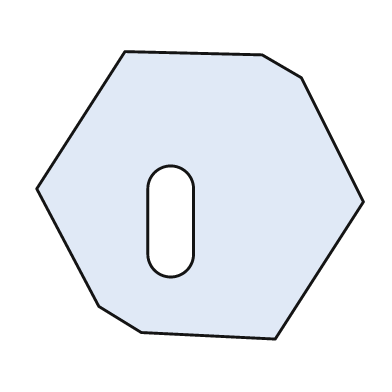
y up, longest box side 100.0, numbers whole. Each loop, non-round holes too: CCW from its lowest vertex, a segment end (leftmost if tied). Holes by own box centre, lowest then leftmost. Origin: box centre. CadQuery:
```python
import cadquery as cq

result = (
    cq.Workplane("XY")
    .moveTo(23.0, -44.0)
    .lineTo(50.0, -2.0)
    .lineTo(31.0, 36.0)
    .lineTo(19.0, 43.0)
    .lineTo(-23.0, 44.0)
    .lineTo(-50.0, 2.0)
    .lineTo(-31.0, -34.0)
    .lineTo(-18.0, -42.0)
    .close()
    .moveTo(-16.0, -18.0)
    .threePointArc((-9.0, -25.0), (-2.0, -18.0))
    .lineTo(-2.0, 2.0)
    .threePointArc((-9.0, 9.0), (-16.0, 2.0))
    .close()
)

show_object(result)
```